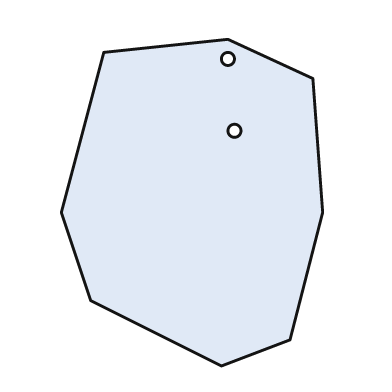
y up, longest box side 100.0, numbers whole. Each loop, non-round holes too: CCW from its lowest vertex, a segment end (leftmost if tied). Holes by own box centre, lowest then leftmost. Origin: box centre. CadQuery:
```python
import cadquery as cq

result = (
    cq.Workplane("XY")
    .moveTo(9.0, -50.0)
    .lineTo(30.0, -42.0)
    .lineTo(40.0, -3.0)
    .lineTo(37.0, 38.0)
    .lineTo(11.0, 50.0)
    .lineTo(-27.0, 46.0)
    .lineTo(-40.0, -3.0)
    .lineTo(-31.0, -30.0)
    .close()
    .moveTo(13.0, 22.0)
    .circle(2.0)
    .moveTo(11.0, 44.0)
    .circle(2.0)
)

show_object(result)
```